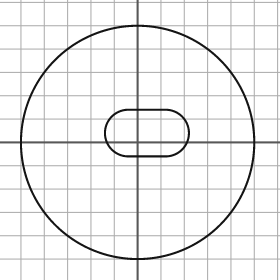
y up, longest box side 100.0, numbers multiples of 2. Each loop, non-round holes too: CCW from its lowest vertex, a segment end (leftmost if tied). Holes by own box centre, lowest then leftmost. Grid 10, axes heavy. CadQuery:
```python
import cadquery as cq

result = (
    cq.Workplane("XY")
    .moveTo(0.0, 0.0)
    .circle(50.0)
    .moveTo(-4.0, -6.0)
    .lineTo(12.0, -6.0)
    .threePointArc((22.0, 4.0), (12.0, 14.0))
    .lineTo(-4.0, 14.0)
    .threePointArc((-14.0, 4.0), (-4.0, -6.0))
    .close()
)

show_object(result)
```